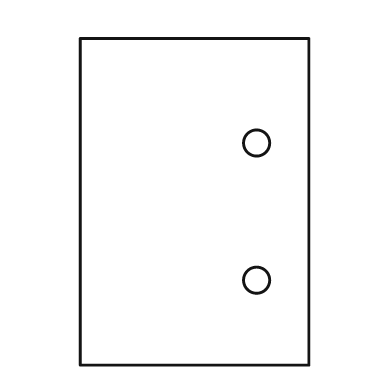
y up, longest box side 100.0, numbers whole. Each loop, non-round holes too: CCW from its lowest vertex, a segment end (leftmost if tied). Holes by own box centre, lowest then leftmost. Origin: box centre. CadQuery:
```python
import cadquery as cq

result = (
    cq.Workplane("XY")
    .moveTo(-35.0, -50.0)
    .lineTo(35.0, -50.0)
    .lineTo(35.0, 50.0)
    .lineTo(-35.0, 50.0)
    .close()
    .moveTo(19.0, -24.0)
    .circle(4.0)
    .moveTo(19.0, 18.0)
    .circle(4.0)
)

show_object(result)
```